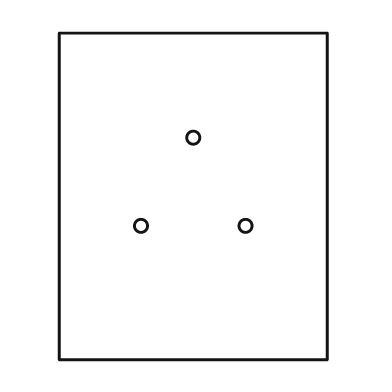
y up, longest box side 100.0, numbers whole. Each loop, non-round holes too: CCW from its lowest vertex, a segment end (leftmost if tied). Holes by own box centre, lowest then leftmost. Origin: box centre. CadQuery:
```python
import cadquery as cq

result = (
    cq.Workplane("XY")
    .moveTo(-41.0, -50.0)
    .lineTo(41.0, -50.0)
    .lineTo(41.0, 50.0)
    .lineTo(-41.0, 50.0)
    .close()
    .moveTo(-16.0, -9.0)
    .circle(2.0)
    .moveTo(16.0, -9.0)
    .circle(2.0)
    .moveTo(0.0, 18.0)
    .circle(2.0)
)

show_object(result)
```